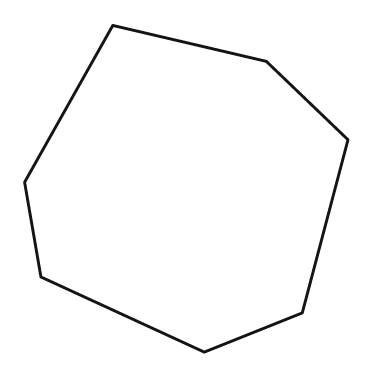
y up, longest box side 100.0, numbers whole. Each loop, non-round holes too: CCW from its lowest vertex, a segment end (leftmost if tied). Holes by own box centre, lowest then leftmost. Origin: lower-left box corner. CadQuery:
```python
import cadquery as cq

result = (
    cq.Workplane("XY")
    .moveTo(55.0, 0.0)
    .lineTo(85.0, 12.0)
    .lineTo(99.0, 65.0)
    .lineTo(74.0, 89.0)
    .lineTo(27.0, 100.0)
    .lineTo(0.0, 52.0)
    .lineTo(5.0, 23.0)
    .close()
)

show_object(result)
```